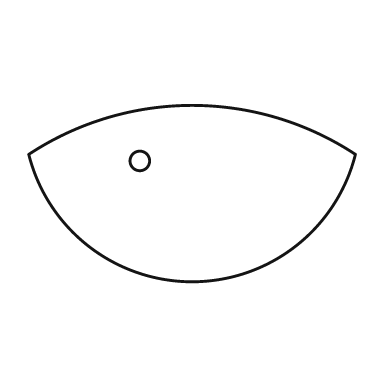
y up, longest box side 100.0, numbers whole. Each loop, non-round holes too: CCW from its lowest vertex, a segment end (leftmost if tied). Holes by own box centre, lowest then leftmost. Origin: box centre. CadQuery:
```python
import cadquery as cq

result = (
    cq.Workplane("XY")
    .moveTo(-50.0, 12.0)
    .threePointArc((0.0, -27.0), (50.0, 12.0))
    .threePointArc((0.0, 27.0), (-50.0, 12.0))
    .close()
    .moveTo(-16.0, 10.0)
    .circle(3.0)
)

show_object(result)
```